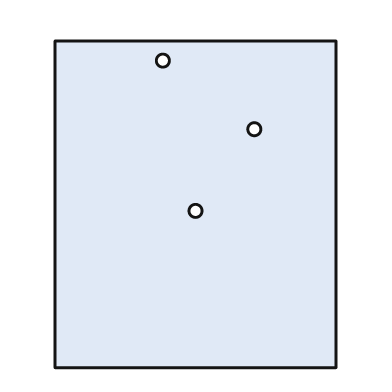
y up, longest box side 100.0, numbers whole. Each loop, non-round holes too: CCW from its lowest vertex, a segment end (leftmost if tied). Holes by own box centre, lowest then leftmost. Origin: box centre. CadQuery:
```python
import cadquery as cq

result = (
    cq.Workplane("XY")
    .moveTo(-43.0, -50.0)
    .lineTo(43.0, -50.0)
    .lineTo(43.0, 50.0)
    .lineTo(-43.0, 50.0)
    .close()
    .moveTo(0.0, -2.0)
    .circle(2.0)
    .moveTo(18.0, 23.0)
    .circle(2.0)
    .moveTo(-10.0, 44.0)
    .circle(2.0)
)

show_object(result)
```